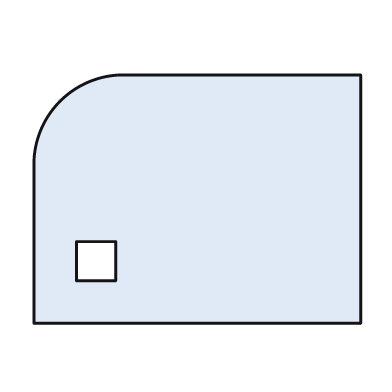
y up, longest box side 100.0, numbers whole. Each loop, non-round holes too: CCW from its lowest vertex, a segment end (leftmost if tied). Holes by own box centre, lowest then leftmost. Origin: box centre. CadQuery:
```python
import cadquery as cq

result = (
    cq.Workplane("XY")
    .moveTo(-50.0, -38.0)
    .lineTo(50.0, -38.0)
    .lineTo(50.0, 38.0)
    .lineTo(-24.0, 38.0)
    .threePointArc((-42.0, 30.0), (-50.0, 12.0))
    .close()
    .moveTo(-37.0, -25.0)
    .lineTo(-25.0, -25.0)
    .lineTo(-25.0, -13.0)
    .lineTo(-37.0, -13.0)
    .close()
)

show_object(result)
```